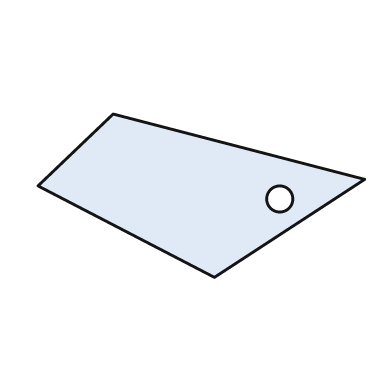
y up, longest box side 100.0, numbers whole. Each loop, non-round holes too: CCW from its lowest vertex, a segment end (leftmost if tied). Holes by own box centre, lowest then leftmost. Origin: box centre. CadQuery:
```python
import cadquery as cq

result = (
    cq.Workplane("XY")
    .moveTo(4.0, -25.0)
    .lineTo(50.0, 5.0)
    .lineTo(-27.0, 25.0)
    .lineTo(-50.0, 3.0)
    .close()
    .moveTo(24.0, -1.0)
    .circle(4.0)
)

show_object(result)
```